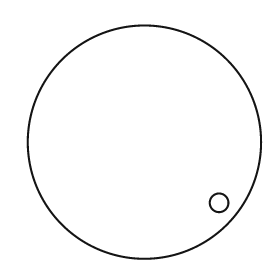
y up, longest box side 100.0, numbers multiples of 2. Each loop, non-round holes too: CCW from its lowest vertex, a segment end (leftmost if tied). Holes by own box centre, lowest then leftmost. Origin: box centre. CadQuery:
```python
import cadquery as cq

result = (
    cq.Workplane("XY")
    .moveTo(0.0, 0.0)
    .circle(50.0)
    .moveTo(32.0, -26.0)
    .circle(4.0)
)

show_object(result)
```